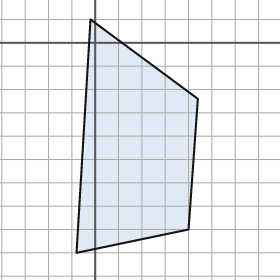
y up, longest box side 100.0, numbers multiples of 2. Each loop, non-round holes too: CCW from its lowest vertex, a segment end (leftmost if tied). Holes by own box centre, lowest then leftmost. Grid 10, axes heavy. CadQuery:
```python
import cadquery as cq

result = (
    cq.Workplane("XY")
    .moveTo(-8.0, -90.0)
    .lineTo(40.0, -80.0)
    .lineTo(44.0, -24.0)
    .lineTo(-2.0, 10.0)
    .close()
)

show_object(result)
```